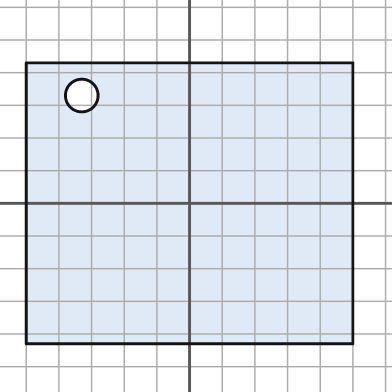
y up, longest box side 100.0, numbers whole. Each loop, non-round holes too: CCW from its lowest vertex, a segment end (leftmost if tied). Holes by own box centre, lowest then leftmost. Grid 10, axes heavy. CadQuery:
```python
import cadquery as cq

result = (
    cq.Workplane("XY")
    .moveTo(-50.0, -43.0)
    .lineTo(50.0, -43.0)
    .lineTo(50.0, 43.0)
    .lineTo(-50.0, 43.0)
    .close()
    .moveTo(-33.0, 33.0)
    .circle(5.0)
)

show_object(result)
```